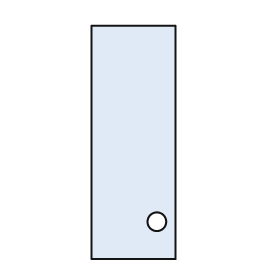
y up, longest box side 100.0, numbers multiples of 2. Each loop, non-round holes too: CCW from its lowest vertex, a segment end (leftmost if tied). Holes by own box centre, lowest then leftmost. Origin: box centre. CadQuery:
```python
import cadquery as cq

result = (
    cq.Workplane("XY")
    .moveTo(-18.0, -50.0)
    .lineTo(18.0, -50.0)
    .lineTo(18.0, 50.0)
    .lineTo(-18.0, 50.0)
    .close()
    .moveTo(10.0, -34.0)
    .circle(4.0)
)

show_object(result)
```